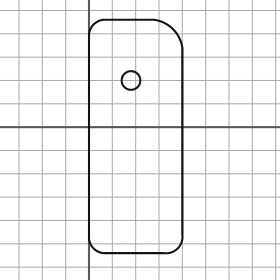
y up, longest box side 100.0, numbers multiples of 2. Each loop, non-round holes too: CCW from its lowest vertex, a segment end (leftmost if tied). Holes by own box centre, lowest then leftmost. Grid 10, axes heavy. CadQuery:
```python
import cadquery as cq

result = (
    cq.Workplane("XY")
    .moveTo(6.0, -54.0)
    .lineTo(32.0, -54.0)
    .threePointArc((38.0, -52.0), (40.0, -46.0))
    .lineTo(40.0, 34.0)
    .threePointArc((36.0, 42.0), (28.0, 46.0))
    .lineTo(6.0, 46.0)
    .threePointArc((2.0, 44.0), (0.0, 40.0))
    .lineTo(0.0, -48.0)
    .threePointArc((2.0, -52.0), (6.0, -54.0))
    .close()
    .moveTo(18.0, 20.0)
    .circle(4.0)
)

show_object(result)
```